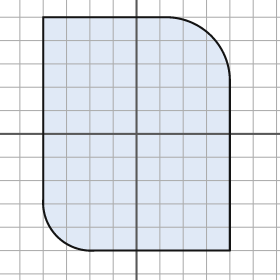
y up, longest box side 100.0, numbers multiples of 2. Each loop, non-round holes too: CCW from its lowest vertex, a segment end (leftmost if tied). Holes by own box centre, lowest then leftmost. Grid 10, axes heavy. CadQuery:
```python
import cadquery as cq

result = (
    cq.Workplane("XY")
    .moveTo(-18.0, -50.0)
    .lineTo(40.0, -50.0)
    .lineTo(40.0, 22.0)
    .threePointArc((32.0, 42.0), (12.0, 50.0))
    .lineTo(-40.0, 50.0)
    .lineTo(-40.0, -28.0)
    .threePointArc((-34.0, -44.0), (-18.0, -50.0))
    .close()
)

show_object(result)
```